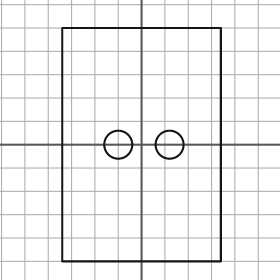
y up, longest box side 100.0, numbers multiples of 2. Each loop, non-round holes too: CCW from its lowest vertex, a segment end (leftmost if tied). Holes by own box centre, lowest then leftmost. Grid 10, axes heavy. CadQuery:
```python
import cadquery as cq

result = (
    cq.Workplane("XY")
    .moveTo(-34.0, -50.0)
    .lineTo(34.0, -50.0)
    .lineTo(34.0, 50.0)
    .lineTo(-34.0, 50.0)
    .close()
    .moveTo(-10.0, 0.0)
    .circle(6.0)
    .moveTo(12.0, 0.0)
    .circle(6.0)
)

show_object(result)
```